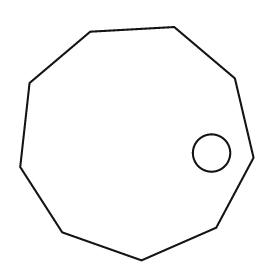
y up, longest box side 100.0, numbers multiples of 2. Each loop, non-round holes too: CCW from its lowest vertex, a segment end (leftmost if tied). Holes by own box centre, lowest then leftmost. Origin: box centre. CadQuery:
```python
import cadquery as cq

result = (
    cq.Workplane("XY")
    .moveTo(2.0, -50.0)
    .lineTo(34.0, -36.0)
    .lineTo(50.0, -6.0)
    .lineTo(42.0, 28.0)
    .lineTo(16.0, 50.0)
    .lineTo(-20.0, 48.0)
    .lineTo(-46.0, 26.0)
    .lineTo(-50.0, -10.0)
    .lineTo(-32.0, -38.0)
    .close()
    .moveTo(32.0, -4.0)
    .circle(8.0)
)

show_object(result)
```